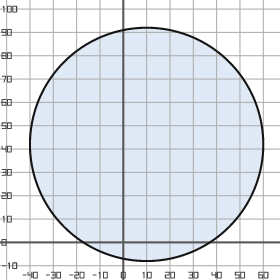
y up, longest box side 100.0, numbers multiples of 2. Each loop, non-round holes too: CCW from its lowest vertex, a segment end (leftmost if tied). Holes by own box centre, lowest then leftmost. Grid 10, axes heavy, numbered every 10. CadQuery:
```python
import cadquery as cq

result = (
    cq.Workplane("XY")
    .moveTo(10.0, 42.0)
    .circle(50.0)
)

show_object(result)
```